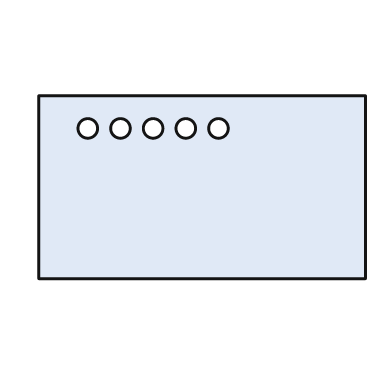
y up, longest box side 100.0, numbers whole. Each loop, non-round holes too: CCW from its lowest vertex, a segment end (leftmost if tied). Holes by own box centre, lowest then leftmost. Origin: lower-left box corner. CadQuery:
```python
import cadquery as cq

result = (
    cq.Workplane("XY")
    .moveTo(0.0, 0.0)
    .lineTo(100.0, 0.0)
    .lineTo(100.0, 56.0)
    .lineTo(0.0, 56.0)
    .close()
    .moveTo(15.0, 46.0)
    .circle(3.0)
    .moveTo(25.0, 46.0)
    .circle(3.0)
    .moveTo(35.0, 46.0)
    .circle(3.0)
    .moveTo(45.0, 46.0)
    .circle(3.0)
    .moveTo(55.0, 46.0)
    .circle(3.0)
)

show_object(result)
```